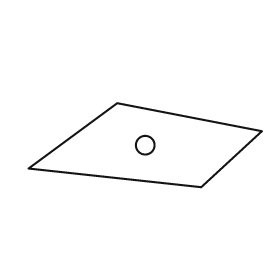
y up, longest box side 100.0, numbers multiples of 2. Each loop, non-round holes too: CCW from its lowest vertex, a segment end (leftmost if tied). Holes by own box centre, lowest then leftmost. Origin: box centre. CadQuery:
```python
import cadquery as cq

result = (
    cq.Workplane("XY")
    .moveTo(24.0, -18.0)
    .lineTo(50.0, 6.0)
    .lineTo(-12.0, 18.0)
    .lineTo(-50.0, -10.0)
    .close()
    .moveTo(0.0, 0.0)
    .circle(4.0)
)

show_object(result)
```